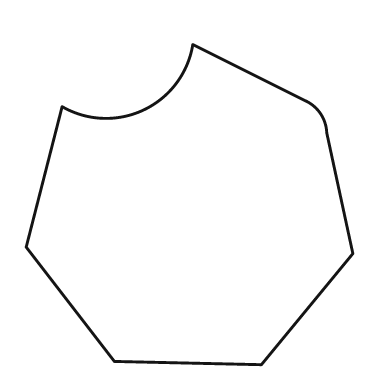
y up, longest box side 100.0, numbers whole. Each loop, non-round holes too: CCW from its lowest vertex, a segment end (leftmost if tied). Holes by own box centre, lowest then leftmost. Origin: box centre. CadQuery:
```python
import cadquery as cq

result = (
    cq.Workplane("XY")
    .moveTo(22.0, -49.0)
    .lineTo(50.0, -15.0)
    .lineTo(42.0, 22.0)
    .threePointArc((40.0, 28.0), (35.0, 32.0))
    .lineTo(1.0, 49.0)
    .threePointArc((-14.0, 29.0), (-39.0, 30.0))
    .lineTo(-50.0, -13.0)
    .lineTo(-23.0, -48.0)
    .close()
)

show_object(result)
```